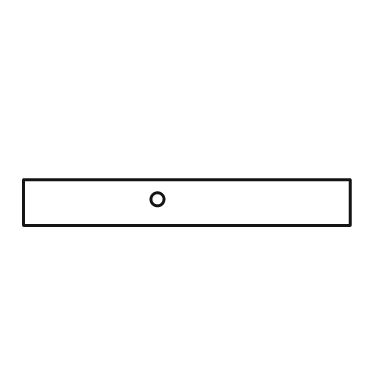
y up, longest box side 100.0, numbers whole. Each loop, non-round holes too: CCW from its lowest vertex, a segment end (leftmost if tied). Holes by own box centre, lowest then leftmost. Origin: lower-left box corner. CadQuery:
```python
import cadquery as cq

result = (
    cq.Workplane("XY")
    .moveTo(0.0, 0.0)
    .lineTo(100.0, 0.0)
    .lineTo(100.0, 14.0)
    .lineTo(0.0, 14.0)
    .close()
    .moveTo(41.0, 8.0)
    .circle(2.0)
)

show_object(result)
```